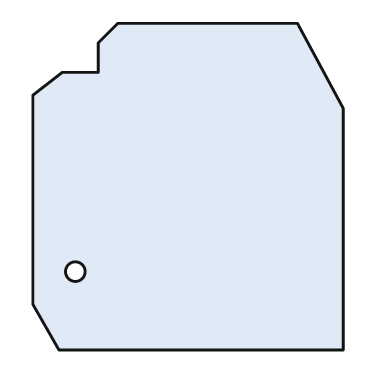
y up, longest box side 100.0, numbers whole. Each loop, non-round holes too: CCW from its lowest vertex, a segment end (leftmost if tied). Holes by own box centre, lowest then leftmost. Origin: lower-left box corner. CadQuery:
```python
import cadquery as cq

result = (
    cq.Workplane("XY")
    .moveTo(8.0, 0.0)
    .lineTo(95.0, 0.0)
    .lineTo(95.0, 74.0)
    .lineTo(81.0, 100.0)
    .lineTo(26.0, 100.0)
    .lineTo(20.0, 94.0)
    .lineTo(20.0, 85.0)
    .lineTo(9.0, 85.0)
    .lineTo(0.0, 78.0)
    .lineTo(0.0, 14.0)
    .close()
    .moveTo(13.0, 24.0)
    .circle(3.0)
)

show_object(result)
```